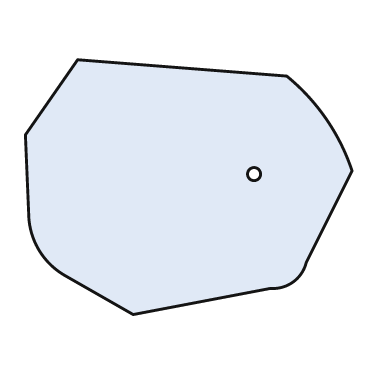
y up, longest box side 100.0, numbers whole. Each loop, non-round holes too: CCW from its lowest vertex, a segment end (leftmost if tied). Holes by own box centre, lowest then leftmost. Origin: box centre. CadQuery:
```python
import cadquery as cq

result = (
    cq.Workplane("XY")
    .moveTo(-17.0, -39.0)
    .lineTo(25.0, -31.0)
    .threePointArc((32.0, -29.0), (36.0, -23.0))
    .lineTo(50.0, 5.0)
    .threePointArc((42.0, 21.0), (30.0, 34.0))
    .lineTo(-34.0, 39.0)
    .lineTo(-50.0, 16.0)
    .lineTo(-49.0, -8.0)
    .threePointArc((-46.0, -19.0), (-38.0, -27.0))
    .close()
    .moveTo(20.0, 4.0)
    .circle(2.0)
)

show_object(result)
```